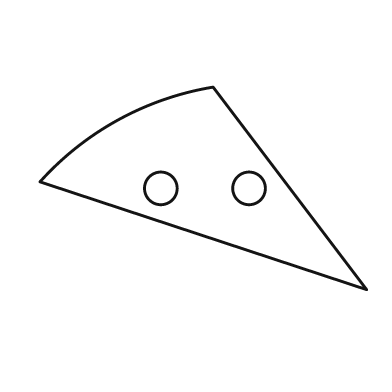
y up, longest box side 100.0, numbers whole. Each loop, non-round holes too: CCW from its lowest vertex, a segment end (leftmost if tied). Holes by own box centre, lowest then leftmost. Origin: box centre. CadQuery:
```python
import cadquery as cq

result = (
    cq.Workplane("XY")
    .moveTo(50.0, -31.0)
    .lineTo(3.0, 31.0)
    .threePointArc((-26.0, 21.0), (-50.0, 2.0))
    .close()
    .moveTo(-13.0, 0.0)
    .circle(5.0)
    .moveTo(14.0, 0.0)
    .circle(5.0)
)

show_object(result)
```